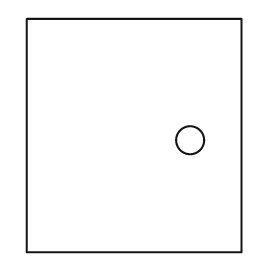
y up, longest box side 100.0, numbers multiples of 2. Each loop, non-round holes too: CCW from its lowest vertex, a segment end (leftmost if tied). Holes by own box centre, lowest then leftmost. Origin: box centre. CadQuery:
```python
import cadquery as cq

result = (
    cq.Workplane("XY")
    .moveTo(-46.0, -50.0)
    .lineTo(46.0, -50.0)
    .lineTo(46.0, 50.0)
    .lineTo(-46.0, 50.0)
    .close()
    .moveTo(24.0, -2.0)
    .circle(6.0)
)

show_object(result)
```